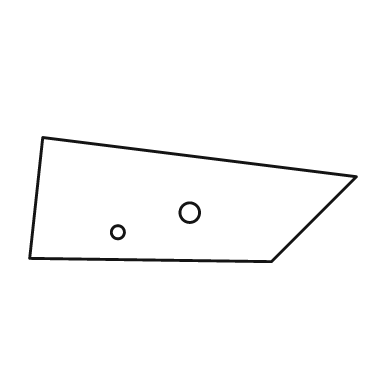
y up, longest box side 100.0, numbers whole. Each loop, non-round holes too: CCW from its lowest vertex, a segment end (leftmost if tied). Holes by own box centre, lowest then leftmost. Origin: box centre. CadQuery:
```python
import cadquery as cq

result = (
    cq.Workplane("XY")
    .moveTo(24.0, -19.0)
    .lineTo(50.0, 7.0)
    .lineTo(-46.0, 19.0)
    .lineTo(-50.0, -18.0)
    .close()
    .moveTo(-23.0, -10.0)
    .circle(2.0)
    .moveTo(-1.0, -4.0)
    .circle(3.0)
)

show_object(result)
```